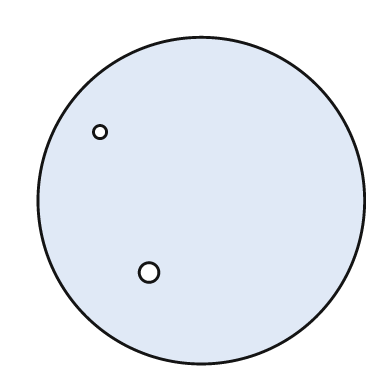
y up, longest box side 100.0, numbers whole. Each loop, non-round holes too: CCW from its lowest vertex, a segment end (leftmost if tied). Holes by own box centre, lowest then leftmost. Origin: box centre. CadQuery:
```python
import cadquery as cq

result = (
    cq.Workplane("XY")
    .moveTo(0.0, 0.0)
    .circle(50.0)
    .moveTo(-16.0, -22.0)
    .circle(3.0)
    .moveTo(-31.0, 21.0)
    .circle(2.0)
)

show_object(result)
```